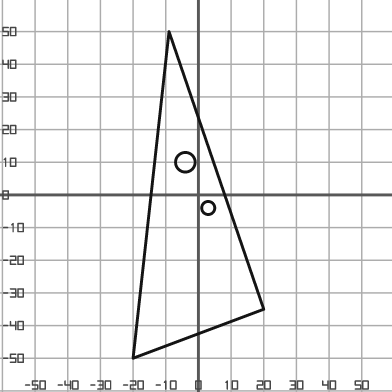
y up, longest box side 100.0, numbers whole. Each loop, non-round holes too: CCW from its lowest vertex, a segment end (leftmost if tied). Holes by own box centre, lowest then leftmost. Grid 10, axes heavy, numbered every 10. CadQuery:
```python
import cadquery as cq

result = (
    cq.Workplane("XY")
    .moveTo(-20.0, -50.0)
    .lineTo(20.0, -35.0)
    .lineTo(-9.0, 50.0)
    .close()
    .moveTo(3.0, -4.0)
    .circle(2.0)
    .moveTo(-4.0, 10.0)
    .circle(3.0)
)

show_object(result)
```